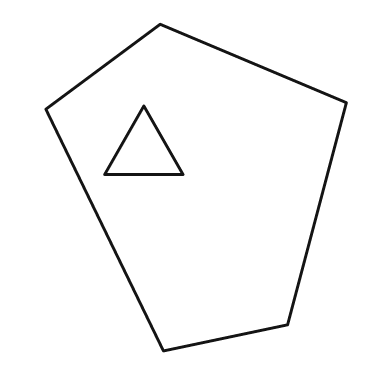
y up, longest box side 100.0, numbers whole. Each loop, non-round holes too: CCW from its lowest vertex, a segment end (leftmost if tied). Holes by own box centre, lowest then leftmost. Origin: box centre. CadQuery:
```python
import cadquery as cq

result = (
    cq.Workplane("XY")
    .moveTo(-10.0, -50.0)
    .lineTo(28.0, -42.0)
    .lineTo(46.0, 26.0)
    .lineTo(-11.0, 50.0)
    .lineTo(-46.0, 24.0)
    .close()
    .moveTo(-28.0, 4.0)
    .lineTo(-4.0, 4.0)
    .lineTo(-16.0, 25.0)
    .close()
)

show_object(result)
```